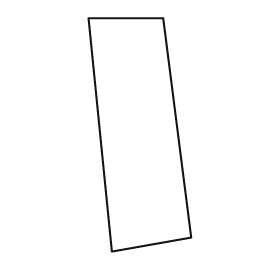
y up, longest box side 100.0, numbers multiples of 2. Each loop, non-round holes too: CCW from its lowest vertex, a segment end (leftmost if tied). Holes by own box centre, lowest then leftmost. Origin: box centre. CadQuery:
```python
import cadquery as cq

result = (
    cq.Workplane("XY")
    .moveTo(-12.0, -50.0)
    .lineTo(22.0, -44.0)
    .lineTo(10.0, 50.0)
    .lineTo(-22.0, 50.0)
    .close()
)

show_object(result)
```